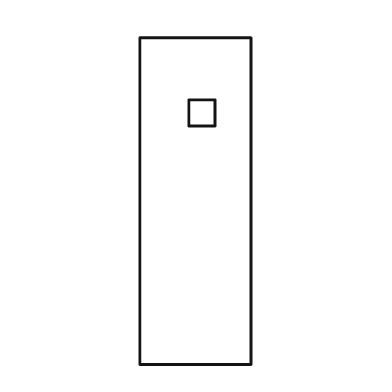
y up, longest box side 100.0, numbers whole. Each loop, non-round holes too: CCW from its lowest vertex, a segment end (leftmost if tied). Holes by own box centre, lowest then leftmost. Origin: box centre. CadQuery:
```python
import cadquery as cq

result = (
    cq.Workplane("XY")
    .moveTo(-17.0, -50.0)
    .lineTo(17.0, -50.0)
    .lineTo(17.0, 50.0)
    .lineTo(-17.0, 50.0)
    .close()
    .moveTo(-2.0, 23.0)
    .lineTo(6.0, 23.0)
    .lineTo(6.0, 31.0)
    .lineTo(-2.0, 31.0)
    .close()
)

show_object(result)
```